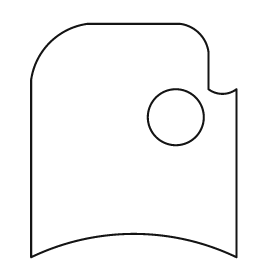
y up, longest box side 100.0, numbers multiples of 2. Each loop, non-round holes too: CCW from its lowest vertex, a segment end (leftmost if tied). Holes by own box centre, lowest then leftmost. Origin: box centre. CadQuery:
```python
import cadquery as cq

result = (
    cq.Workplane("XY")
    .moveTo(-44.0, -50.0)
    .threePointArc((0.0, -40.0), (44.0, -50.0))
    .lineTo(44.0, 22.0)
    .threePointArc((38.0, 20.0), (32.0, 22.0))
    .lineTo(32.0, 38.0)
    .threePointArc((28.0, 46.0), (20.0, 50.0))
    .lineTo(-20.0, 50.0)
    .threePointArc((-36.0, 42.0), (-44.0, 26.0))
    .close()
    .moveTo(18.0, 10.0)
    .circle(12.0)
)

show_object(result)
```